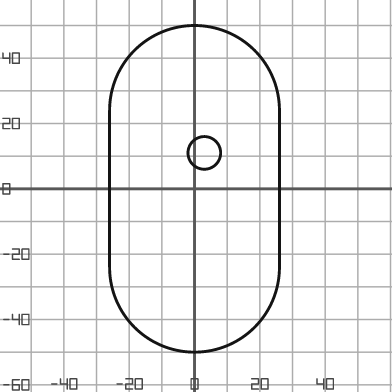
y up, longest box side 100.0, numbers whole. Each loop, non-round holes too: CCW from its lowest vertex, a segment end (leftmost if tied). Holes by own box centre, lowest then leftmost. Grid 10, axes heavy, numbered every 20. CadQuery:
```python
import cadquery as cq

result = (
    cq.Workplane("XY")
    .moveTo(-26.0, -24.0)
    .threePointArc((0.0, -50.0), (26.0, -24.0))
    .lineTo(26.0, 24.0)
    .threePointArc((0.0, 50.0), (-26.0, 24.0))
    .close()
    .moveTo(3.0, 11.0)
    .circle(5.0)
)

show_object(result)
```